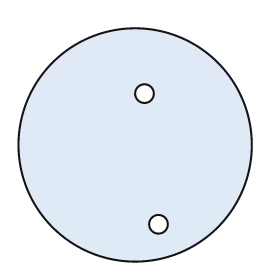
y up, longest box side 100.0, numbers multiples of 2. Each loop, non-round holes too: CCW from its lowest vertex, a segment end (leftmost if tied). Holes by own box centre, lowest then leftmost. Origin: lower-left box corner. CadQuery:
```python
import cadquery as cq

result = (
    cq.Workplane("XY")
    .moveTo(50.0, 50.0)
    .circle(50.0)
    .moveTo(60.0, 16.0)
    .circle(4.0)
    .moveTo(54.0, 72.0)
    .circle(4.0)
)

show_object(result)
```